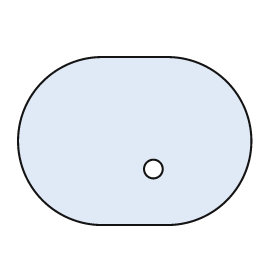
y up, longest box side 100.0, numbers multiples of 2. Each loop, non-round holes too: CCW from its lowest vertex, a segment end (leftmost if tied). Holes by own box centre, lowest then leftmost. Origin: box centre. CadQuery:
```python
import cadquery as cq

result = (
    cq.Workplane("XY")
    .moveTo(-14.0, -36.0)
    .lineTo(14.0, -36.0)
    .threePointArc((50.0, 0.0), (14.0, 36.0))
    .lineTo(-14.0, 36.0)
    .threePointArc((-50.0, 0.0), (-14.0, -36.0))
    .close()
    .moveTo(8.0, -12.0)
    .circle(4.0)
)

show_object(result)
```